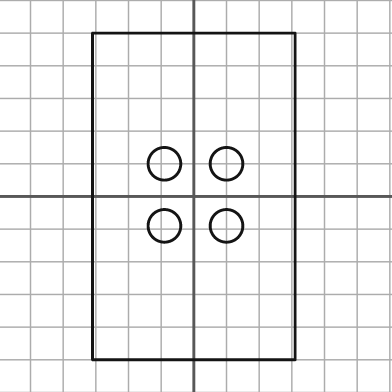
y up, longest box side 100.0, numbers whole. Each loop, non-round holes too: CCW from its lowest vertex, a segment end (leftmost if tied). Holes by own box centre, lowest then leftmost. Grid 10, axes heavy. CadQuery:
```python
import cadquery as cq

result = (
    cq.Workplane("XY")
    .moveTo(-31.0, -50.0)
    .lineTo(31.0, -50.0)
    .lineTo(31.0, 50.0)
    .lineTo(-31.0, 50.0)
    .close()
    .moveTo(-9.0, -9.0)
    .circle(5.0)
    .moveTo(10.0, -9.0)
    .circle(5.0)
    .moveTo(-9.0, 10.0)
    .circle(5.0)
    .moveTo(10.0, 10.0)
    .circle(5.0)
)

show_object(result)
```